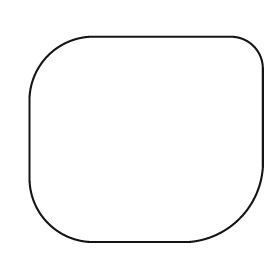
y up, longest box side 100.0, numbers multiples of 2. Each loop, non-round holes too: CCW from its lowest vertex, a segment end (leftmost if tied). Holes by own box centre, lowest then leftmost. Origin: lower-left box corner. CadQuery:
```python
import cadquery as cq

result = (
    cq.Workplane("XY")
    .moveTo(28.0, 0.0)
    .lineTo(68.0, 0.0)
    .threePointArc((90.0, 10.0), (100.0, 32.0))
    .lineTo(100.0, 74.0)
    .threePointArc((96.0, 84.0), (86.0, 88.0))
    .lineTo(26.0, 88.0)
    .threePointArc((8.0, 80.0), (0.0, 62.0))
    .lineTo(0.0, 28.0)
    .threePointArc((8.0, 8.0), (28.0, 0.0))
    .close()
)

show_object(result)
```